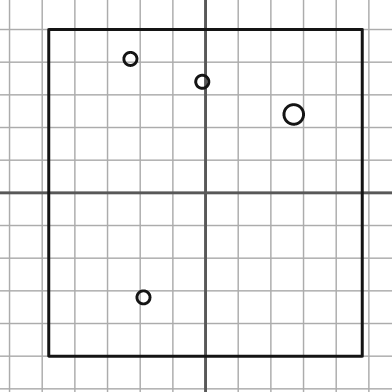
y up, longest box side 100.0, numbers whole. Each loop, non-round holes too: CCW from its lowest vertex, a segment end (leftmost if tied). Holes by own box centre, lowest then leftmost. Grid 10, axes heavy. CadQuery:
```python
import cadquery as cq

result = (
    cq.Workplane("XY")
    .moveTo(-48.0, -50.0)
    .lineTo(48.0, -50.0)
    .lineTo(48.0, 50.0)
    .lineTo(-48.0, 50.0)
    .close()
    .moveTo(-19.0, -32.0)
    .circle(2.0)
    .moveTo(27.0, 24.0)
    .circle(3.0)
    .moveTo(-1.0, 34.0)
    .circle(2.0)
    .moveTo(-23.0, 41.0)
    .circle(2.0)
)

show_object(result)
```